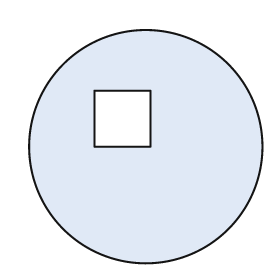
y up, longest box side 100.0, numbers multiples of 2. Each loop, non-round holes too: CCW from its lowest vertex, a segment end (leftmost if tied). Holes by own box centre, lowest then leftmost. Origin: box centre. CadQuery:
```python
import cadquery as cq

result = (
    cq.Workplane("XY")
    .moveTo(0.0, 0.0)
    .circle(50.0)
    .moveTo(-22.0, 0.0)
    .lineTo(2.0, 0.0)
    .lineTo(2.0, 24.0)
    .lineTo(-22.0, 24.0)
    .close()
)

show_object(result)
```